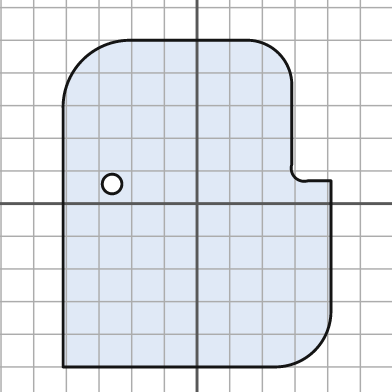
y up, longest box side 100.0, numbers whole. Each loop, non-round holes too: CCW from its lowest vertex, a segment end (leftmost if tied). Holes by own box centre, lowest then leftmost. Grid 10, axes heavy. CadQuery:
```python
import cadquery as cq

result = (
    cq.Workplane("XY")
    .moveTo(-41.0, -50.0)
    .lineTo(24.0, -50.0)
    .threePointArc((36.0, -45.0), (41.0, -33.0))
    .lineTo(41.0, 7.0)
    .lineTo(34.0, 7.0)
    .threePointArc((30.0, 8.0), (29.0, 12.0))
    .lineTo(29.0, 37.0)
    .threePointArc((25.0, 46.0), (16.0, 50.0))
    .lineTo(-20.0, 50.0)
    .threePointArc((-35.0, 44.0), (-41.0, 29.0))
    .close()
    .moveTo(-26.0, 6.0)
    .circle(3.0)
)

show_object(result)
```